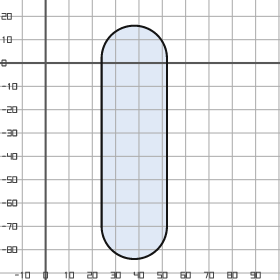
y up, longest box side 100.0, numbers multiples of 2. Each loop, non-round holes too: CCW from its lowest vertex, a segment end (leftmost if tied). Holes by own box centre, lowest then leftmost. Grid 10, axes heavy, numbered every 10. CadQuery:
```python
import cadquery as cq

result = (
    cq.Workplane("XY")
    .moveTo(24.0, -70.0)
    .threePointArc((38.0, -84.0), (52.0, -70.0))
    .lineTo(52.0, 2.0)
    .threePointArc((38.0, 16.0), (24.0, 2.0))
    .close()
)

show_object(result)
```